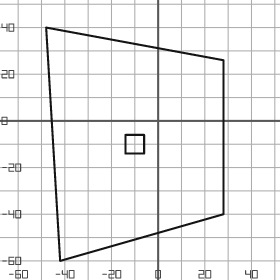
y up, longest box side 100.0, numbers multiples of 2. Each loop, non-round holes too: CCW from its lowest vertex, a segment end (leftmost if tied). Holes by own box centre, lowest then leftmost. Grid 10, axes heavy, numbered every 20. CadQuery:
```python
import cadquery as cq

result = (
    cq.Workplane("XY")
    .moveTo(-42.0, -60.0)
    .lineTo(28.0, -40.0)
    .lineTo(28.0, 26.0)
    .lineTo(-48.0, 40.0)
    .close()
    .moveTo(-14.0, -14.0)
    .lineTo(-6.0, -14.0)
    .lineTo(-6.0, -6.0)
    .lineTo(-14.0, -6.0)
    .close()
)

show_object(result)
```